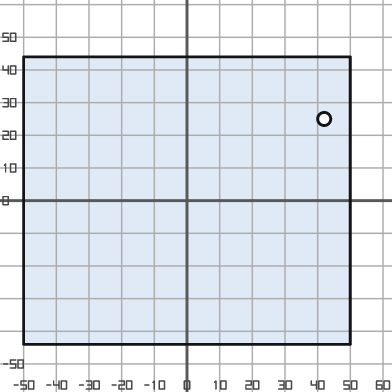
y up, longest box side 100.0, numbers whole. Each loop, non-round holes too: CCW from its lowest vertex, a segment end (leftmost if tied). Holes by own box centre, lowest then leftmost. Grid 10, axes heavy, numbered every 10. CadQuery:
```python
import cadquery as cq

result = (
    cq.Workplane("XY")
    .moveTo(-50.0, -44.0)
    .lineTo(50.0, -44.0)
    .lineTo(50.0, 44.0)
    .lineTo(-50.0, 44.0)
    .close()
    .moveTo(42.0, 25.0)
    .circle(2.0)
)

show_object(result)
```